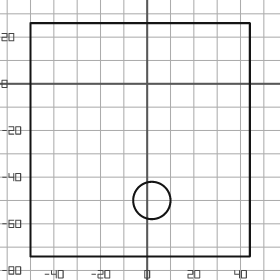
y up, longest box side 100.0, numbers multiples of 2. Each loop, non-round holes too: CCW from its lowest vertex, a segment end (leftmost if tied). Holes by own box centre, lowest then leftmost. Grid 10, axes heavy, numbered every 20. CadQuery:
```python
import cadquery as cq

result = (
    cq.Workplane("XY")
    .moveTo(-50.0, -74.0)
    .lineTo(44.0, -74.0)
    .lineTo(44.0, 26.0)
    .lineTo(-50.0, 26.0)
    .close()
    .moveTo(2.0, -50.0)
    .circle(8.0)
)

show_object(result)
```